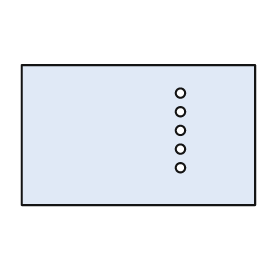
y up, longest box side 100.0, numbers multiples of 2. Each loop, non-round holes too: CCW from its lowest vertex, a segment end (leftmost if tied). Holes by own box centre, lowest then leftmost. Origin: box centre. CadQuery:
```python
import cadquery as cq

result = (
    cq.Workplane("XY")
    .moveTo(-50.0, -30.0)
    .lineTo(50.0, -30.0)
    .lineTo(50.0, 30.0)
    .lineTo(-50.0, 30.0)
    .close()
    .moveTo(18.0, -14.0)
    .circle(2.0)
    .moveTo(18.0, -6.0)
    .circle(2.0)
    .moveTo(18.0, 2.0)
    .circle(2.0)
    .moveTo(18.0, 10.0)
    .circle(2.0)
    .moveTo(18.0, 18.0)
    .circle(2.0)
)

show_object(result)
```